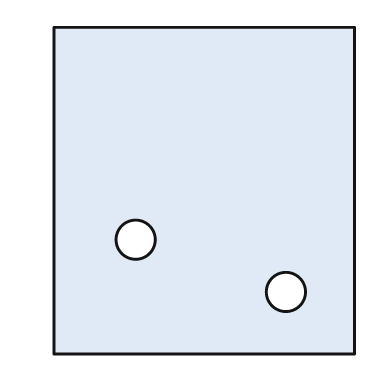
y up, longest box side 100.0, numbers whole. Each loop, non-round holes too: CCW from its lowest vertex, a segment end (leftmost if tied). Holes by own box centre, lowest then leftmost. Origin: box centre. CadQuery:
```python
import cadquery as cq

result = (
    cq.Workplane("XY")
    .moveTo(-46.0, -50.0)
    .lineTo(46.0, -50.0)
    .lineTo(46.0, 50.0)
    .lineTo(-46.0, 50.0)
    .close()
    .moveTo(25.0, -31.0)
    .circle(6.0)
    .moveTo(-21.0, -15.0)
    .circle(6.0)
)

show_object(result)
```